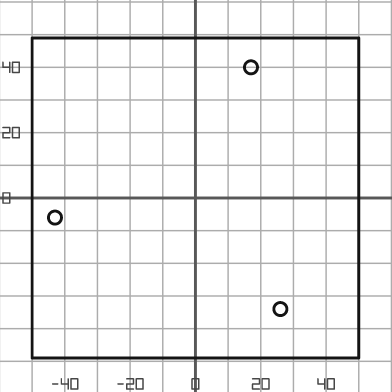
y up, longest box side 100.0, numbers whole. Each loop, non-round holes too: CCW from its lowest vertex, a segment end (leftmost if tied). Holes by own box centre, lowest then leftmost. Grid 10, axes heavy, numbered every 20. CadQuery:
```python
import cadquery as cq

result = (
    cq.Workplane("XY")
    .moveTo(-50.0, -49.0)
    .lineTo(50.0, -49.0)
    .lineTo(50.0, 49.0)
    .lineTo(-50.0, 49.0)
    .close()
    .moveTo(26.0, -34.0)
    .circle(2.0)
    .moveTo(-43.0, -6.0)
    .circle(2.0)
    .moveTo(17.0, 40.0)
    .circle(2.0)
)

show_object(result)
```